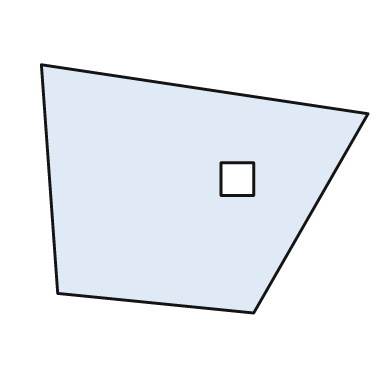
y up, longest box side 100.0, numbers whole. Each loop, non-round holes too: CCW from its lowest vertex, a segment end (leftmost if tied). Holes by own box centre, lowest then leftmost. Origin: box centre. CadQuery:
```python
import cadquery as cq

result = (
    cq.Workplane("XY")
    .moveTo(15.0, -38.0)
    .lineTo(50.0, 23.0)
    .lineTo(-50.0, 38.0)
    .lineTo(-45.0, -32.0)
    .close()
    .moveTo(5.0, -2.0)
    .lineTo(15.0, -2.0)
    .lineTo(15.0, 8.0)
    .lineTo(5.0, 8.0)
    .close()
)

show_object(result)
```